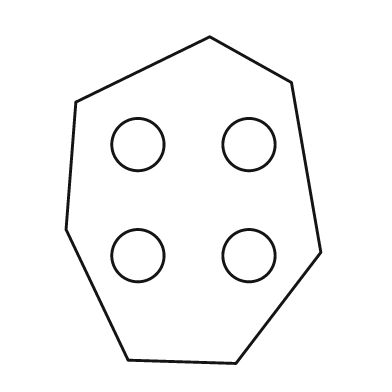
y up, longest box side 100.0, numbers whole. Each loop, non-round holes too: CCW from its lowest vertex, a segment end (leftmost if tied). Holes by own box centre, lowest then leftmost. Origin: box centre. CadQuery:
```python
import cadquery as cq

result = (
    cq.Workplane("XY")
    .moveTo(13.0, -50.0)
    .lineTo(39.0, -16.0)
    .lineTo(30.0, 36.0)
    .lineTo(5.0, 50.0)
    .lineTo(-36.0, 30.0)
    .lineTo(-39.0, -9.0)
    .lineTo(-20.0, -49.0)
    .close()
    .moveTo(-17.0, -17.0)
    .circle(8.0)
    .moveTo(17.0, -17.0)
    .circle(8.0)
    .moveTo(-17.0, 17.0)
    .circle(8.0)
    .moveTo(17.0, 17.0)
    .circle(8.0)
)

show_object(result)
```